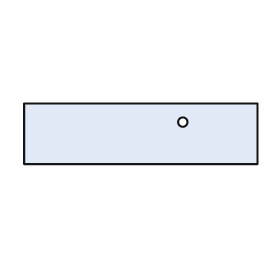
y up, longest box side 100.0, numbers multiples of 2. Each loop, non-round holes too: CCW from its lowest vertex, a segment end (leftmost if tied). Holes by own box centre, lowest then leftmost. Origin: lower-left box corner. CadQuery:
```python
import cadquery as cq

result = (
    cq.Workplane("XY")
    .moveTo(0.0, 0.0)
    .lineTo(100.0, 0.0)
    .lineTo(100.0, 26.0)
    .lineTo(0.0, 26.0)
    .close()
    .moveTo(68.0, 18.0)
    .circle(2.0)
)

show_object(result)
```